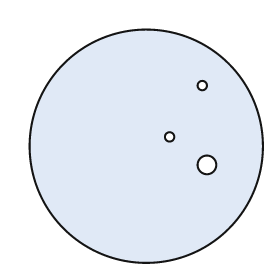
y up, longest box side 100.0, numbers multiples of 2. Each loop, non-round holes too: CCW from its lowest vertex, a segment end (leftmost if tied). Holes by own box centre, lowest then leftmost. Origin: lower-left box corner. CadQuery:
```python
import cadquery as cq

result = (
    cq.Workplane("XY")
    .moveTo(50.0, 50.0)
    .circle(50.0)
    .moveTo(76.0, 42.0)
    .circle(4.0)
    .moveTo(60.0, 54.0)
    .circle(2.0)
    .moveTo(74.0, 76.0)
    .circle(2.0)
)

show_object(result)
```